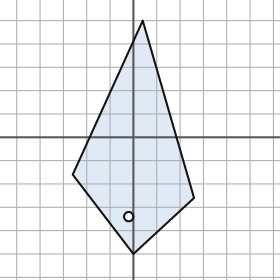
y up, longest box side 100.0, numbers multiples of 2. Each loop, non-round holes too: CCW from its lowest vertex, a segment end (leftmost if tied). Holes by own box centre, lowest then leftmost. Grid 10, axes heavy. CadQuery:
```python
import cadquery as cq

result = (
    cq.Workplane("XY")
    .moveTo(0.0, -50.0)
    .lineTo(26.0, -26.0)
    .lineTo(4.0, 50.0)
    .lineTo(-26.0, -16.0)
    .close()
    .moveTo(-2.0, -34.0)
    .circle(2.0)
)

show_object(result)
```